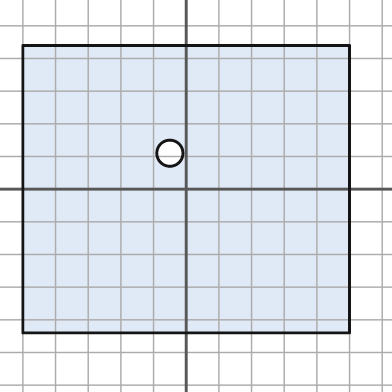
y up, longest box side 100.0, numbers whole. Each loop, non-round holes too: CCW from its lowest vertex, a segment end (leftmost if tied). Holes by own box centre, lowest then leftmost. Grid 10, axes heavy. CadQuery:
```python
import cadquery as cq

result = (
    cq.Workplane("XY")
    .moveTo(-50.0, -44.0)
    .lineTo(50.0, -44.0)
    .lineTo(50.0, 44.0)
    .lineTo(-50.0, 44.0)
    .close()
    .moveTo(-5.0, 11.0)
    .circle(4.0)
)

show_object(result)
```